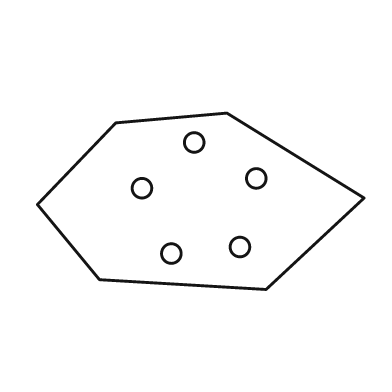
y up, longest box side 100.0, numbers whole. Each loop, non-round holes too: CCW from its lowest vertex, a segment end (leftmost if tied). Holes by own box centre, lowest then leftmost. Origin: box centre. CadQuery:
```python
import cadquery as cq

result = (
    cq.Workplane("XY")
    .moveTo(20.0, -27.0)
    .lineTo(50.0, 1.0)
    .lineTo(8.0, 27.0)
    .lineTo(-26.0, 24.0)
    .lineTo(-50.0, -1.0)
    .lineTo(-31.0, -24.0)
    .close()
    .moveTo(-9.0, -16.0)
    .circle(3.0)
    .moveTo(12.0, -14.0)
    .circle(3.0)
    .moveTo(-18.0, 4.0)
    .circle(3.0)
    .moveTo(17.0, 7.0)
    .circle(3.0)
    .moveTo(-2.0, 18.0)
    .circle(3.0)
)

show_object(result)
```